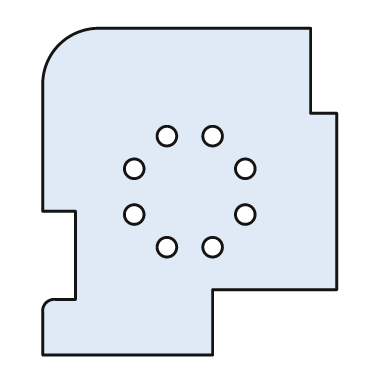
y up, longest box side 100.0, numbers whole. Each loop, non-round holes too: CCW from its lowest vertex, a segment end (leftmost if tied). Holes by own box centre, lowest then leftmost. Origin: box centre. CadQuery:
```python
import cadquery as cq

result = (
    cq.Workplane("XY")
    .moveTo(-45.0, -50.0)
    .lineTo(7.0, -50.0)
    .lineTo(7.0, -30.0)
    .lineTo(45.0, -30.0)
    .lineTo(45.0, 24.0)
    .lineTo(37.0, 24.0)
    .lineTo(37.0, 50.0)
    .lineTo(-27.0, 50.0)
    .threePointArc((-40.0, 45.0), (-45.0, 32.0))
    .lineTo(-45.0, -6.0)
    .lineTo(-35.0, -6.0)
    .lineTo(-35.0, -33.0)
    .lineTo(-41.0, -33.0)
    .threePointArc((-44.0, -34.0), (-45.0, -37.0))
    .close()
    .moveTo(-7.0, -17.0)
    .circle(3.0)
    .moveTo(7.0, -17.0)
    .circle(3.0)
    .moveTo(-17.0, -7.0)
    .circle(3.0)
    .moveTo(17.0, -7.0)
    .circle(3.0)
    .moveTo(-17.0, 7.0)
    .circle(3.0)
    .moveTo(17.0, 7.0)
    .circle(3.0)
    .moveTo(-7.0, 17.0)
    .circle(3.0)
    .moveTo(7.0, 17.0)
    .circle(3.0)
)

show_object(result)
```